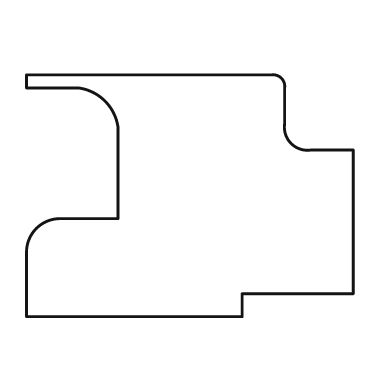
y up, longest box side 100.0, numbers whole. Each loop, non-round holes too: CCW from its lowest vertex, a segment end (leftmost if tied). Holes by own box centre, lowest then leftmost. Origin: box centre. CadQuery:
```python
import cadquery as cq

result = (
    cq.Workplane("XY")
    .moveTo(-50.0, -37.0)
    .lineTo(16.0, -37.0)
    .lineTo(16.0, -30.0)
    .lineTo(50.0, -30.0)
    .lineTo(50.0, 14.0)
    .lineTo(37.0, 14.0)
    .threePointArc((31.0, 16.0), (29.0, 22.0))
    .lineTo(29.0, 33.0)
    .threePointArc((28.0, 36.0), (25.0, 37.0))
    .lineTo(-50.0, 37.0)
    .lineTo(-50.0, 33.0)
    .lineTo(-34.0, 33.0)
    .threePointArc((-26.0, 29.0), (-22.0, 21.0))
    .lineTo(-22.0, -7.0)
    .lineTo(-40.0, -7.0)
    .threePointArc((-47.0, -10.0), (-50.0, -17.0))
    .close()
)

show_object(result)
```